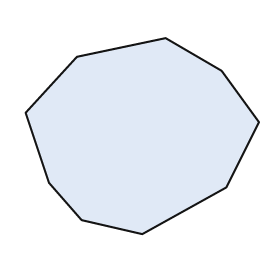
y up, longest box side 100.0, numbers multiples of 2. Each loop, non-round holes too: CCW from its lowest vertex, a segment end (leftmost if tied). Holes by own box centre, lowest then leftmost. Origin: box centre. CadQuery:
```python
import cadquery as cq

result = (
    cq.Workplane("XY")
    .moveTo(0.0, -42.0)
    .lineTo(36.0, -22.0)
    .lineTo(50.0, 6.0)
    .lineTo(34.0, 28.0)
    .lineTo(10.0, 42.0)
    .lineTo(-28.0, 34.0)
    .lineTo(-50.0, 10.0)
    .lineTo(-40.0, -20.0)
    .lineTo(-26.0, -36.0)
    .close()
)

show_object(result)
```